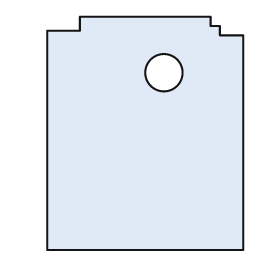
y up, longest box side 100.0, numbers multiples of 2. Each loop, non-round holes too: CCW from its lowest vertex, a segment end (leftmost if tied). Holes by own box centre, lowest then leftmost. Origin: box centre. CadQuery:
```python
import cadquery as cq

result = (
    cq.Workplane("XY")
    .moveTo(-42.0, -50.0)
    .lineTo(42.0, -50.0)
    .lineTo(42.0, 42.0)
    .lineTo(32.0, 42.0)
    .lineTo(32.0, 46.0)
    .lineTo(28.0, 46.0)
    .lineTo(28.0, 50.0)
    .lineTo(-28.0, 50.0)
    .lineTo(-28.0, 44.0)
    .lineTo(-42.0, 44.0)
    .close()
    .moveTo(8.0, 26.0)
    .circle(8.0)
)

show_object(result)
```